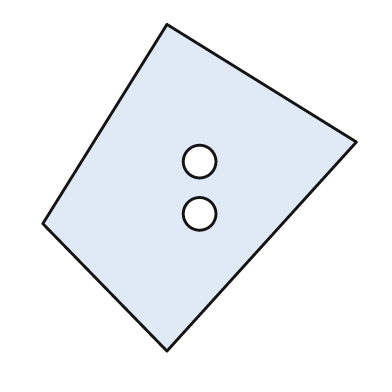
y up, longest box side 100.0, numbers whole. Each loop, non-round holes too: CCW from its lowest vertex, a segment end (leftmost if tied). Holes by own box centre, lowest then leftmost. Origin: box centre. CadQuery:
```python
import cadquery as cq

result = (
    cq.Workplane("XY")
    .moveTo(-10.0, -50.0)
    .lineTo(48.0, 14.0)
    .lineTo(-10.0, 50.0)
    .lineTo(-48.0, -11.0)
    .close()
    .moveTo(0.0, -8.0)
    .circle(5.0)
    .moveTo(0.0, 8.0)
    .circle(5.0)
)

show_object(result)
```